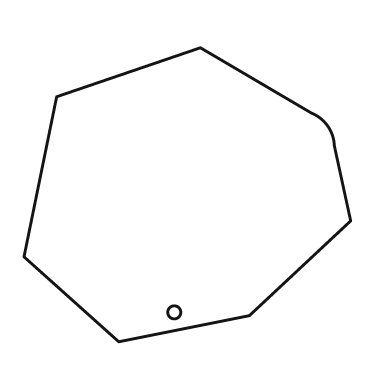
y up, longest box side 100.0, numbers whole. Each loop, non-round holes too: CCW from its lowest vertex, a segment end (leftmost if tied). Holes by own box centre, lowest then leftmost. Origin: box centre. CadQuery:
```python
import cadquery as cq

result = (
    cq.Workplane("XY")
    .moveTo(-21.0, -45.0)
    .lineTo(19.0, -37.0)
    .lineTo(50.0, -8.0)
    .lineTo(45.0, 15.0)
    .threePointArc((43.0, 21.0), (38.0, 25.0))
    .lineTo(4.0, 45.0)
    .lineTo(-40.0, 30.0)
    .lineTo(-50.0, -19.0)
    .close()
    .moveTo(-4.0, -36.0)
    .circle(2.0)
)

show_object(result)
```